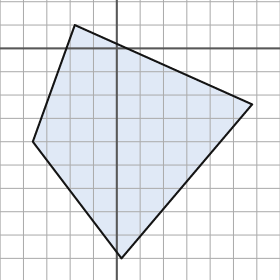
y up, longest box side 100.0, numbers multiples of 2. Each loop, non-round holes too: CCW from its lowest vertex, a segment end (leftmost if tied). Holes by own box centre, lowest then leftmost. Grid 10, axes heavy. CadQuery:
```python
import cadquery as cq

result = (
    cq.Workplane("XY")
    .moveTo(2.0, -90.0)
    .lineTo(58.0, -24.0)
    .lineTo(-18.0, 10.0)
    .lineTo(-36.0, -40.0)
    .close()
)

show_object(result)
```